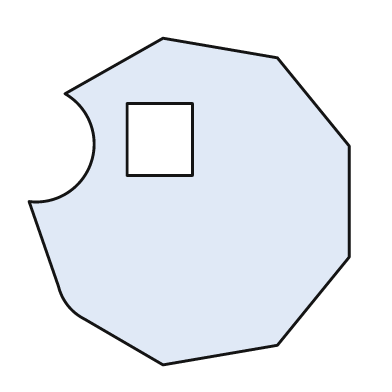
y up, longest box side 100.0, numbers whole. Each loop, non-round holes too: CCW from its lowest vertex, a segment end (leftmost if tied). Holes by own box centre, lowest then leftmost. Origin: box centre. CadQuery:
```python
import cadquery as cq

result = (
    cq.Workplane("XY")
    .moveTo(-8.0, -50.0)
    .lineTo(27.0, -44.0)
    .lineTo(49.0, -17.0)
    .lineTo(49.0, 17.0)
    .lineTo(27.0, 44.0)
    .lineTo(-8.0, 50.0)
    .lineTo(-38.0, 33.0)
    .threePointArc((-30.0, 12.0), (-49.0, 0.0))
    .lineTo(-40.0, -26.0)
    .threePointArc((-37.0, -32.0), (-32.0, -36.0))
    .close()
    .moveTo(-19.0, 8.0)
    .lineTo(1.0, 8.0)
    .lineTo(1.0, 30.0)
    .lineTo(-19.0, 30.0)
    .close()
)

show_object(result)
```